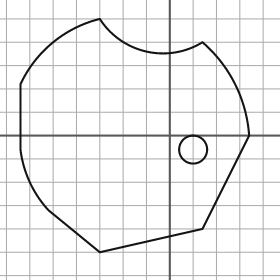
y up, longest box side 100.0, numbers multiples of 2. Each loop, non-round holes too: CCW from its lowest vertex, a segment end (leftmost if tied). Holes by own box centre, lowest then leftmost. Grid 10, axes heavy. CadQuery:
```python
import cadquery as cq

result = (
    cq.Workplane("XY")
    .moveTo(-30.0, -50.0)
    .lineTo(14.0, -40.0)
    .lineTo(34.0, 0.0)
    .threePointArc((28.0, 22.0), (14.0, 40.0))
    .threePointArc((-10.0, 36.0), (-30.0, 50.0))
    .threePointArc((-50.0, 40.0), (-64.0, 22.0))
    .lineTo(-64.0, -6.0)
    .threePointArc((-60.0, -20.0), (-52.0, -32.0))
    .close()
    .moveTo(10.0, -6.0)
    .circle(6.0)
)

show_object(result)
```